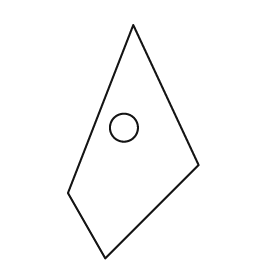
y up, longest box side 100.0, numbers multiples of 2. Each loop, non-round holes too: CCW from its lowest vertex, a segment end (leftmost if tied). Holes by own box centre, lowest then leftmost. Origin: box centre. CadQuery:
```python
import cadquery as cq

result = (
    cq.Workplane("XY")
    .moveTo(-12.0, -50.0)
    .lineTo(28.0, -10.0)
    .lineTo(0.0, 50.0)
    .lineTo(-28.0, -22.0)
    .close()
    .moveTo(-4.0, 6.0)
    .circle(6.0)
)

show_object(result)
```